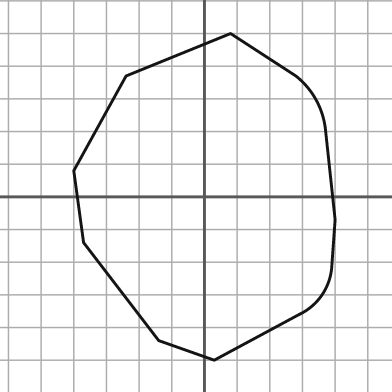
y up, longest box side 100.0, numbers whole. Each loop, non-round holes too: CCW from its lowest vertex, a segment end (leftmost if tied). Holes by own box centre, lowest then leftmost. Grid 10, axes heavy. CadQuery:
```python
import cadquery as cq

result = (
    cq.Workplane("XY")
    .moveTo(3.0, -50.0)
    .lineTo(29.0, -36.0)
    .threePointArc((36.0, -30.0), (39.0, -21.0))
    .lineTo(40.0, -7.0)
    .lineTo(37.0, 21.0)
    .threePointArc((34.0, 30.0), (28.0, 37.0))
    .lineTo(8.0, 50.0)
    .lineTo(-24.0, 37.0)
    .lineTo(-40.0, 8.0)
    .lineTo(-37.0, -14.0)
    .lineTo(-14.0, -44.0)
    .close()
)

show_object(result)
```